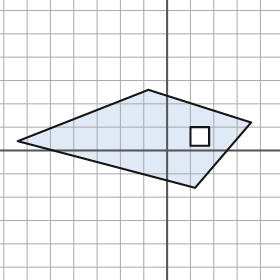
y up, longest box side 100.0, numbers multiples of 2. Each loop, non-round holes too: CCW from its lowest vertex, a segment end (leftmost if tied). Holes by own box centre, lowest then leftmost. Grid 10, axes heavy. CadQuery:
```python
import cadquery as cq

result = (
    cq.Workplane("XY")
    .moveTo(12.0, -16.0)
    .lineTo(36.0, 12.0)
    .lineTo(-8.0, 26.0)
    .lineTo(-64.0, 4.0)
    .close()
    .moveTo(10.0, 2.0)
    .lineTo(18.0, 2.0)
    .lineTo(18.0, 10.0)
    .lineTo(10.0, 10.0)
    .close()
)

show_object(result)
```